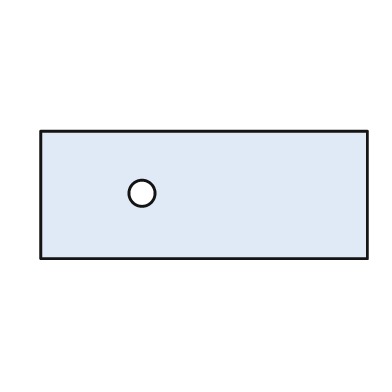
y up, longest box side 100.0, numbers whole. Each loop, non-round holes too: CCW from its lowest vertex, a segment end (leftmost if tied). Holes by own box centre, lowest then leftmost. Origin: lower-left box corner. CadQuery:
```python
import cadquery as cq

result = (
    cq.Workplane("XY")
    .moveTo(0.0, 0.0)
    .lineTo(100.0, 0.0)
    .lineTo(100.0, 39.0)
    .lineTo(0.0, 39.0)
    .close()
    .moveTo(31.0, 20.0)
    .circle(4.0)
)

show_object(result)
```